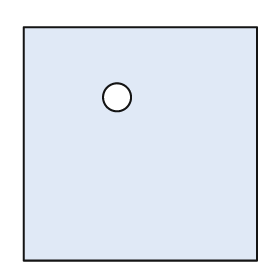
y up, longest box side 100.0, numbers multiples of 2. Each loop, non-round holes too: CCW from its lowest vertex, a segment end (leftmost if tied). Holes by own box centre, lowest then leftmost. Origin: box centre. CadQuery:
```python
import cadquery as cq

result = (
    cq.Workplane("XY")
    .moveTo(-50.0, -50.0)
    .lineTo(50.0, -50.0)
    .lineTo(50.0, 50.0)
    .lineTo(-50.0, 50.0)
    .close()
    .moveTo(-10.0, 20.0)
    .circle(6.0)
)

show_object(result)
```